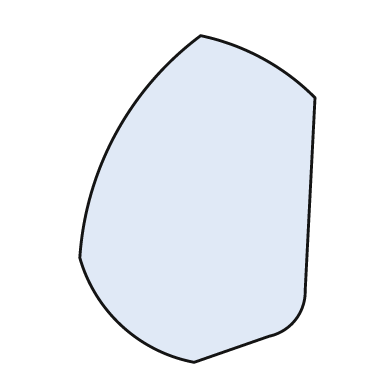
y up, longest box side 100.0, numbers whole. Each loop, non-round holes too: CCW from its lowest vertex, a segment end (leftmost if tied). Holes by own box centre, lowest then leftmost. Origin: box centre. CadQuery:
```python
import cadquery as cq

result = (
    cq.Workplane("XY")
    .moveTo(-1.0, -50.0)
    .lineTo(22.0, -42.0)
    .threePointArc((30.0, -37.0), (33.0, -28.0))
    .lineTo(36.0, 31.0)
    .threePointArc((20.0, 43.0), (1.0, 50.0))
    .threePointArc((-25.0, 20.0), (-36.0, -18.0))
    .threePointArc((-23.0, -39.0), (-1.0, -50.0))
    .close()
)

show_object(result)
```